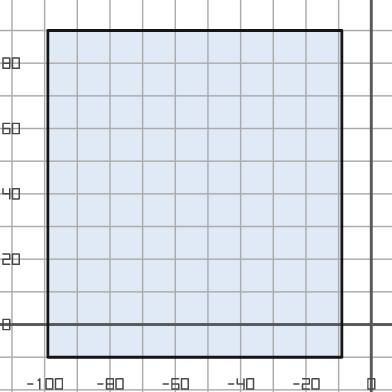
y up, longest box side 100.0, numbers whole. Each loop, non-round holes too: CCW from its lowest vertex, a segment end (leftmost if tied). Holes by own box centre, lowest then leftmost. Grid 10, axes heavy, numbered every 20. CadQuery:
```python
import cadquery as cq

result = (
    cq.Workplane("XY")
    .moveTo(-99.0, -10.0)
    .lineTo(-9.0, -10.0)
    .lineTo(-9.0, 90.0)
    .lineTo(-99.0, 90.0)
    .close()
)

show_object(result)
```